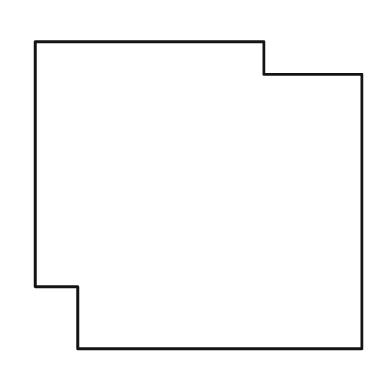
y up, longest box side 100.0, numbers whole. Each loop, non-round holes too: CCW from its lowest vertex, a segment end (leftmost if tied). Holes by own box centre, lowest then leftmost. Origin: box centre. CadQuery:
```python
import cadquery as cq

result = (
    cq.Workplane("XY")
    .moveTo(-37.0, -47.0)
    .lineTo(50.0, -47.0)
    .lineTo(50.0, 37.0)
    .lineTo(20.0, 37.0)
    .lineTo(20.0, 47.0)
    .lineTo(-50.0, 47.0)
    .lineTo(-50.0, -28.0)
    .lineTo(-37.0, -28.0)
    .close()
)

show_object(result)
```